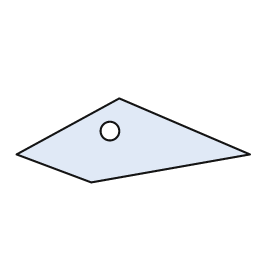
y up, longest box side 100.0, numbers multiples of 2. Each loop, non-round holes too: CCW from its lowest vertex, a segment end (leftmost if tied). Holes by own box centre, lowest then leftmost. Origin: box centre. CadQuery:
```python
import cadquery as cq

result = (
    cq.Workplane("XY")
    .moveTo(-18.0, -18.0)
    .lineTo(50.0, -6.0)
    .lineTo(-6.0, 18.0)
    .lineTo(-50.0, -6.0)
    .close()
    .moveTo(-10.0, 4.0)
    .circle(4.0)
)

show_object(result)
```